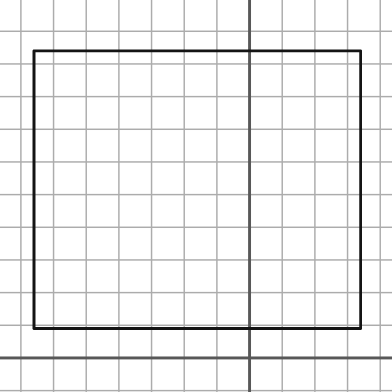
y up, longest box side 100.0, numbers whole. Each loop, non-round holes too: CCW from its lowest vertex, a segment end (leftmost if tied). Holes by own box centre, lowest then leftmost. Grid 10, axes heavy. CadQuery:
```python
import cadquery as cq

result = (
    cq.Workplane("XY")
    .moveTo(-66.0, 9.0)
    .lineTo(34.0, 9.0)
    .lineTo(34.0, 94.0)
    .lineTo(-66.0, 94.0)
    .close()
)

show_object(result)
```